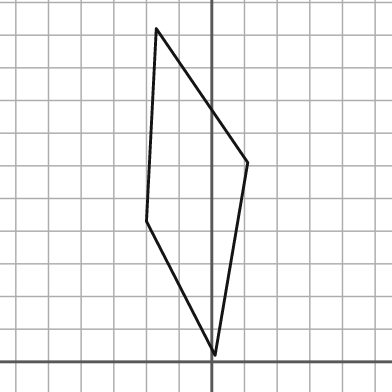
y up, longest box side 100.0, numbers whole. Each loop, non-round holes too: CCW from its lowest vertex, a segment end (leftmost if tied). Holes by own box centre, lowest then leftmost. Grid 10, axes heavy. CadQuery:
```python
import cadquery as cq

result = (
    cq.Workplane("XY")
    .moveTo(1.0, 2.0)
    .lineTo(11.0, 61.0)
    .lineTo(-17.0, 102.0)
    .lineTo(-20.0, 43.0)
    .close()
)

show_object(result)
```